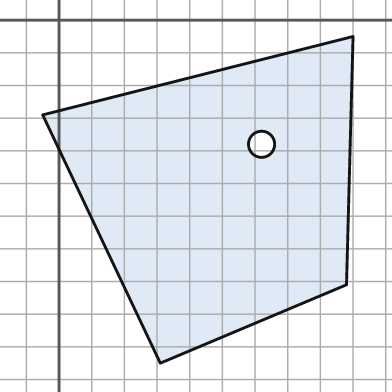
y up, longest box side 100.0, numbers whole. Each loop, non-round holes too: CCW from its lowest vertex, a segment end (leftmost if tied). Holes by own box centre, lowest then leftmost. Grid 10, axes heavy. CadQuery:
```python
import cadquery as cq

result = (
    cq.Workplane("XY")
    .moveTo(31.0, -105.0)
    .lineTo(88.0, -81.0)
    .lineTo(90.0, -5.0)
    .lineTo(-5.0, -29.0)
    .close()
    .moveTo(62.0, -38.0)
    .circle(4.0)
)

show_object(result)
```